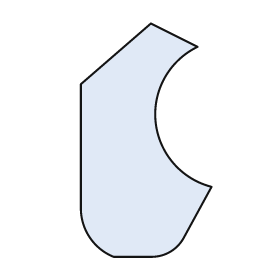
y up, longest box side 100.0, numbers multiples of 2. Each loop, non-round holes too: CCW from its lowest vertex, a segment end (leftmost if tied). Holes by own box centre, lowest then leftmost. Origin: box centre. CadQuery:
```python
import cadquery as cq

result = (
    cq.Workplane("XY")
    .moveTo(-14.0, -50.0)
    .lineTo(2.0, -50.0)
    .threePointArc((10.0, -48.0), (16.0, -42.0))
    .lineTo(28.0, -20.0)
    .threePointArc((4.0, 8.0), (22.0, 40.0))
    .lineTo(2.0, 50.0)
    .lineTo(-28.0, 24.0)
    .lineTo(-28.0, -30.0)
    .threePointArc((-24.0, -42.0), (-14.0, -50.0))
    .close()
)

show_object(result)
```